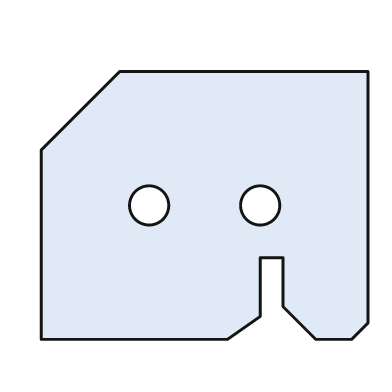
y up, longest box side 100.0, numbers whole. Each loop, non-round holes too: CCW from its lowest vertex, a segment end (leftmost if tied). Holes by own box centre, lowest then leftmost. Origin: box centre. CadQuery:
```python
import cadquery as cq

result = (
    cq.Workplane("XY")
    .moveTo(-50.0, -41.0)
    .lineTo(7.0, -41.0)
    .lineTo(17.0, -34.0)
    .lineTo(17.0, -16.0)
    .lineTo(24.0, -16.0)
    .lineTo(24.0, -31.0)
    .lineTo(34.0, -41.0)
    .lineTo(45.0, -41.0)
    .lineTo(50.0, -36.0)
    .lineTo(50.0, 41.0)
    .lineTo(-26.0, 41.0)
    .lineTo(-50.0, 17.0)
    .close()
    .moveTo(-17.0, 0.0)
    .circle(6.0)
    .moveTo(17.0, 0.0)
    .circle(6.0)
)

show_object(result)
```